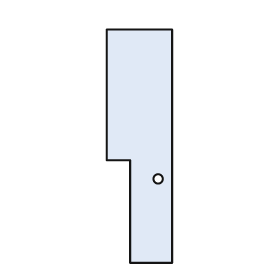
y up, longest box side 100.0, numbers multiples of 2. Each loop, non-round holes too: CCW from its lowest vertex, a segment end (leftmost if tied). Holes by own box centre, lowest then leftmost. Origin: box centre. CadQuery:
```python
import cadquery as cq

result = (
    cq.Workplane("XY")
    .moveTo(-4.0, -50.0)
    .lineTo(14.0, -50.0)
    .lineTo(14.0, 50.0)
    .lineTo(-14.0, 50.0)
    .lineTo(-14.0, -6.0)
    .lineTo(-4.0, -6.0)
    .close()
    .moveTo(8.0, -14.0)
    .circle(2.0)
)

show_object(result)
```